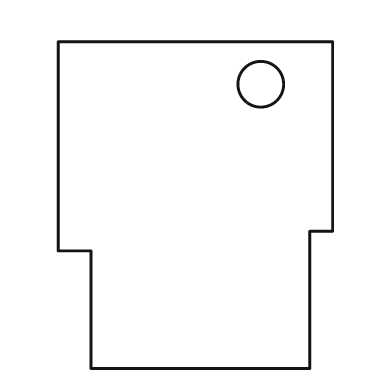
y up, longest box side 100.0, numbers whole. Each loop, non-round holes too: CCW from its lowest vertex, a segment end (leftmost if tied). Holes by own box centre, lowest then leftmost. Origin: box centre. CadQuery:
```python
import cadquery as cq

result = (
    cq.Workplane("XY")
    .moveTo(-32.0, -50.0)
    .lineTo(35.0, -50.0)
    .lineTo(35.0, -8.0)
    .lineTo(42.0, -8.0)
    .lineTo(42.0, 50.0)
    .lineTo(-42.0, 50.0)
    .lineTo(-42.0, -14.0)
    .lineTo(-32.0, -14.0)
    .close()
    .moveTo(20.0, 37.0)
    .circle(7.0)
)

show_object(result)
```